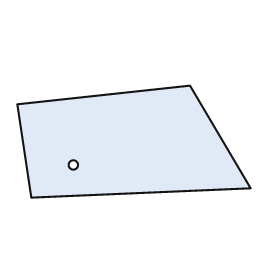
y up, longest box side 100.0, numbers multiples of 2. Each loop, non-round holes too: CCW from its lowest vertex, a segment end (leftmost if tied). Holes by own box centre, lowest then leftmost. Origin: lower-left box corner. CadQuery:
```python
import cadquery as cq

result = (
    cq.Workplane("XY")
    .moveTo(6.0, 0.0)
    .lineTo(100.0, 4.0)
    .lineTo(74.0, 48.0)
    .lineTo(0.0, 40.0)
    .close()
    .moveTo(24.0, 14.0)
    .circle(2.0)
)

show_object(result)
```